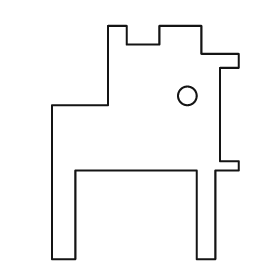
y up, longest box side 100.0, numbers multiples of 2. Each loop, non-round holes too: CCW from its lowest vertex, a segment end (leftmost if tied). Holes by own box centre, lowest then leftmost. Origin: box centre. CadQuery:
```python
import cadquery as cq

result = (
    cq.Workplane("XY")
    .moveTo(-40.0, -50.0)
    .lineTo(-30.0, -50.0)
    .lineTo(-30.0, -12.0)
    .lineTo(22.0, -12.0)
    .lineTo(22.0, -50.0)
    .lineTo(30.0, -50.0)
    .lineTo(30.0, -12.0)
    .lineTo(40.0, -12.0)
    .lineTo(40.0, -8.0)
    .lineTo(32.0, -8.0)
    .lineTo(32.0, 32.0)
    .lineTo(40.0, 32.0)
    .lineTo(40.0, 38.0)
    .lineTo(24.0, 38.0)
    .lineTo(24.0, 50.0)
    .lineTo(6.0, 50.0)
    .lineTo(6.0, 42.0)
    .lineTo(-8.0, 42.0)
    .lineTo(-8.0, 50.0)
    .lineTo(-16.0, 50.0)
    .lineTo(-16.0, 16.0)
    .lineTo(-40.0, 16.0)
    .close()
    .moveTo(18.0, 20.0)
    .circle(4.0)
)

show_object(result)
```